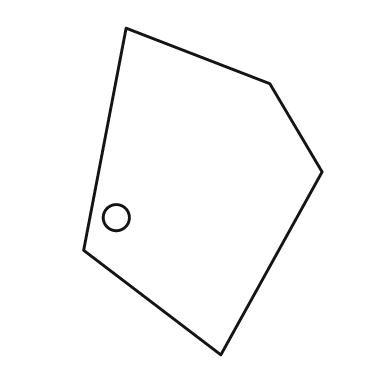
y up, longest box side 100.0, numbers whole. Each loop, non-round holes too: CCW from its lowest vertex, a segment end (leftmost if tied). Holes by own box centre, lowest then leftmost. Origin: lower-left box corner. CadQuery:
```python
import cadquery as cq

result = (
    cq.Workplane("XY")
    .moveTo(42.0, 0.0)
    .lineTo(73.0, 56.0)
    .lineTo(57.0, 83.0)
    .lineTo(13.0, 100.0)
    .lineTo(0.0, 32.0)
    .close()
    .moveTo(10.0, 42.0)
    .circle(4.0)
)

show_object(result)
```